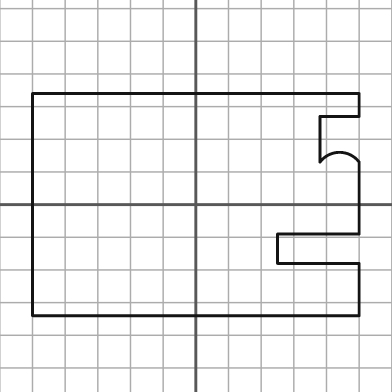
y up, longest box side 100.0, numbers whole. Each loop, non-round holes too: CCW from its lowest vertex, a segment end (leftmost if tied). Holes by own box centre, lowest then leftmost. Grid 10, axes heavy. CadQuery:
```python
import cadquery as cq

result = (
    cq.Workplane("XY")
    .moveTo(-50.0, -34.0)
    .lineTo(50.0, -34.0)
    .lineTo(50.0, -18.0)
    .lineTo(25.0, -18.0)
    .lineTo(25.0, -9.0)
    .lineTo(50.0, -9.0)
    .lineTo(50.0, 13.0)
    .threePointArc((44.0, 16.0), (38.0, 13.0))
    .lineTo(38.0, 27.0)
    .lineTo(50.0, 27.0)
    .lineTo(50.0, 34.0)
    .lineTo(-50.0, 34.0)
    .close()
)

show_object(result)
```